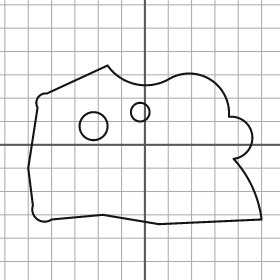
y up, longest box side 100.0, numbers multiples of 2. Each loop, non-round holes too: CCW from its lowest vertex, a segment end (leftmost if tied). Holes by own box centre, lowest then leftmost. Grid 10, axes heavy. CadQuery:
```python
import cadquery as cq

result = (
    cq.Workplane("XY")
    .moveTo(6.0, -34.0)
    .lineTo(50.0, -32.0)
    .threePointArc((46.0, -18.0), (38.0, -6.0))
    .threePointArc((46.0, 4.0), (36.0, 12.0))
    .threePointArc((28.0, 28.0), (10.0, 28.0))
    .threePointArc((-4.0, 26.0), (-16.0, 34.0))
    .lineTo(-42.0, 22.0)
    .threePointArc((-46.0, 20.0), (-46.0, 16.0))
    .lineTo(-50.0, -10.0)
    .lineTo(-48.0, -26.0)
    .threePointArc((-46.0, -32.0), (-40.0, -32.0))
    .lineTo(-18.0, -30.0)
    .close()
    .moveTo(-22.0, 8.0)
    .circle(6.0)
    .moveTo(-2.0, 14.0)
    .circle(4.0)
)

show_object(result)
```